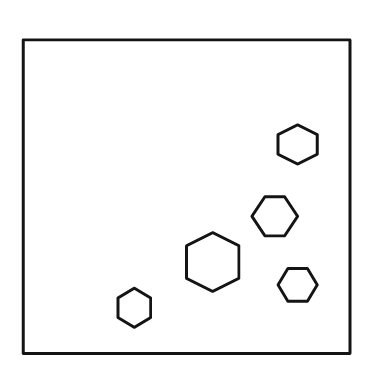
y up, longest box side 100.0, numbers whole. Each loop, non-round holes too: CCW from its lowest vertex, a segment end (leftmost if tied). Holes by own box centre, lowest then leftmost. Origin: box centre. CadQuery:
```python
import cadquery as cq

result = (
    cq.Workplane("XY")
    .moveTo(-50.0, -48.0)
    .lineTo(50.0, -48.0)
    .lineTo(50.0, 48.0)
    .lineTo(-50.0, 48.0)
    .close()
    .moveTo(-16.0, -40.0)
    .lineTo(-11.0, -37.0)
    .lineTo(-11.0, -31.0)
    .lineTo(-16.0, -28.0)
    .lineTo(-21.0, -31.0)
    .lineTo(-21.0, -37.0)
    .close()
    .moveTo(31.0, -32.0)
    .lineTo(37.0, -32.0)
    .lineTo(40.0, -27.0)
    .lineTo(37.0, -22.0)
    .lineTo(31.0, -22.0)
    .lineTo(28.0, -27.0)
    .close()
    .moveTo(8.0, -29.0)
    .lineTo(16.0, -25.0)
    .lineTo(16.0, -15.0)
    .lineTo(8.0, -11.0)
    .lineTo(0.0, -15.0)
    .lineTo(0.0, -25.0)
    .close()
    .moveTo(24.0, -12.0)
    .lineTo(30.0, -12.0)
    .lineTo(34.0, -6.0)
    .lineTo(30.0, 0.0)
    .lineTo(24.0, 0.0)
    .lineTo(20.0, -6.0)
    .close()
    .moveTo(34.0, 10.0)
    .lineTo(40.0, 13.0)
    .lineTo(40.0, 19.0)
    .lineTo(34.0, 22.0)
    .lineTo(28.0, 19.0)
    .lineTo(28.0, 13.0)
    .close()
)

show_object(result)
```